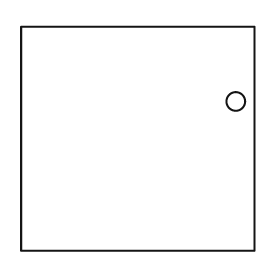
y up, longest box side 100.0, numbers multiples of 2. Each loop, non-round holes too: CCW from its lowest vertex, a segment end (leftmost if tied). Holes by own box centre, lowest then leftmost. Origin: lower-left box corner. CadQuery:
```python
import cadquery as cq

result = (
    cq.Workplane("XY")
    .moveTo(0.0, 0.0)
    .lineTo(100.0, 0.0)
    .lineTo(100.0, 96.0)
    .lineTo(0.0, 96.0)
    .close()
    .moveTo(92.0, 64.0)
    .circle(4.0)
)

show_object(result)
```